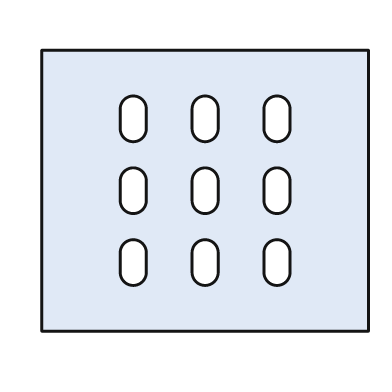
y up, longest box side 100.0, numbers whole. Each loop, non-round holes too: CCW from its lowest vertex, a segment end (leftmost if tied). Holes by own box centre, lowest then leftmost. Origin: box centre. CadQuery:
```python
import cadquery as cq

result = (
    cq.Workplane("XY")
    .moveTo(-50.0, -43.0)
    .lineTo(50.0, -43.0)
    .lineTo(50.0, 43.0)
    .lineTo(-50.0, 43.0)
    .close()
    .moveTo(-26.0, -25.0)
    .threePointArc((-22.0, -29.0), (-18.0, -25.0))
    .lineTo(-18.0, -19.0)
    .threePointArc((-22.0, -15.0), (-26.0, -19.0))
    .close()
    .moveTo(-4.0, -25.0)
    .threePointArc((0.0, -29.0), (4.0, -25.0))
    .lineTo(4.0, -19.0)
    .threePointArc((0.0, -15.0), (-4.0, -19.0))
    .close()
    .moveTo(18.0, -25.0)
    .threePointArc((22.0, -29.0), (26.0, -25.0))
    .lineTo(26.0, -19.0)
    .threePointArc((22.0, -15.0), (18.0, -19.0))
    .close()
    .moveTo(-26.0, -3.0)
    .threePointArc((-22.0, -7.0), (-18.0, -3.0))
    .lineTo(-18.0, 3.0)
    .threePointArc((-22.0, 7.0), (-26.0, 3.0))
    .close()
    .moveTo(-4.0, -3.0)
    .threePointArc((0.0, -7.0), (4.0, -3.0))
    .lineTo(4.0, 3.0)
    .threePointArc((0.0, 7.0), (-4.0, 3.0))
    .close()
    .moveTo(18.0, -3.0)
    .threePointArc((22.0, -7.0), (26.0, -3.0))
    .lineTo(26.0, 3.0)
    .threePointArc((22.0, 7.0), (18.0, 3.0))
    .close()
    .moveTo(-26.0, 19.0)
    .threePointArc((-22.0, 15.0), (-18.0, 19.0))
    .lineTo(-18.0, 25.0)
    .threePointArc((-22.0, 29.0), (-26.0, 25.0))
    .close()
    .moveTo(-4.0, 19.0)
    .threePointArc((0.0, 15.0), (4.0, 19.0))
    .lineTo(4.0, 25.0)
    .threePointArc((0.0, 29.0), (-4.0, 25.0))
    .close()
    .moveTo(18.0, 19.0)
    .threePointArc((22.0, 15.0), (26.0, 19.0))
    .lineTo(26.0, 25.0)
    .threePointArc((22.0, 29.0), (18.0, 25.0))
    .close()
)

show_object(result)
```